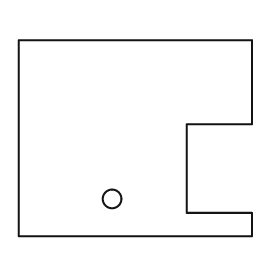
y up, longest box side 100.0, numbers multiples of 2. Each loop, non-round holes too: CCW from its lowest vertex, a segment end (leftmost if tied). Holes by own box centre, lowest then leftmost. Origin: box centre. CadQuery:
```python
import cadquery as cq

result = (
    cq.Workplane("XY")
    .moveTo(-50.0, -42.0)
    .lineTo(50.0, -42.0)
    .lineTo(50.0, -32.0)
    .lineTo(22.0, -32.0)
    .lineTo(22.0, 6.0)
    .lineTo(50.0, 6.0)
    .lineTo(50.0, 42.0)
    .lineTo(-50.0, 42.0)
    .close()
    .moveTo(-10.0, -26.0)
    .circle(4.0)
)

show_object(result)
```